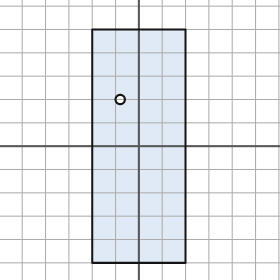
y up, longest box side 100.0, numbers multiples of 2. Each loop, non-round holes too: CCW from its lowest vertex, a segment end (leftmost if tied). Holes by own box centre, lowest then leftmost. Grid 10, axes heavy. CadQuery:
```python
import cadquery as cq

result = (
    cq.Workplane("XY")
    .moveTo(-20.0, -50.0)
    .lineTo(20.0, -50.0)
    .lineTo(20.0, 50.0)
    .lineTo(-20.0, 50.0)
    .close()
    .moveTo(-8.0, 20.0)
    .circle(2.0)
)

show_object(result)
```